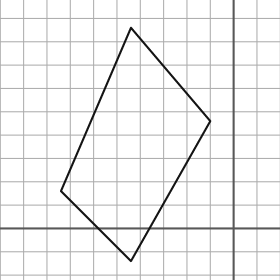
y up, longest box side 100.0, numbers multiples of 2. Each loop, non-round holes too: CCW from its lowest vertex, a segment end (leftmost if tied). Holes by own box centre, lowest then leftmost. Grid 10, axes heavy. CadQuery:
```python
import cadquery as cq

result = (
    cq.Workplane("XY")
    .moveTo(-44.0, -14.0)
    .lineTo(-10.0, 46.0)
    .lineTo(-44.0, 86.0)
    .lineTo(-74.0, 16.0)
    .close()
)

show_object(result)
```